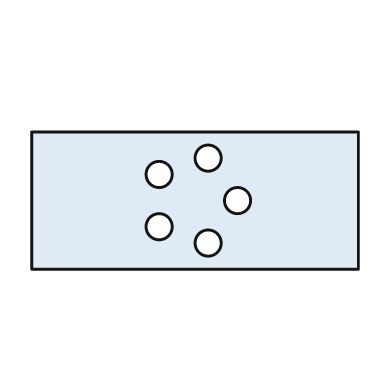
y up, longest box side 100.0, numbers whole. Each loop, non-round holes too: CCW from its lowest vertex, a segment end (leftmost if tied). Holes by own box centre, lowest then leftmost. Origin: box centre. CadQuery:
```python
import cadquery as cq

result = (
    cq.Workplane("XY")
    .moveTo(-50.0, -21.0)
    .lineTo(50.0, -21.0)
    .lineTo(50.0, 21.0)
    .lineTo(-50.0, 21.0)
    .close()
    .moveTo(4.0, -13.0)
    .circle(4.0)
    .moveTo(-11.0, -8.0)
    .circle(4.0)
    .moveTo(13.0, 0.0)
    .circle(4.0)
    .moveTo(-11.0, 8.0)
    .circle(4.0)
    .moveTo(4.0, 13.0)
    .circle(4.0)
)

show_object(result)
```